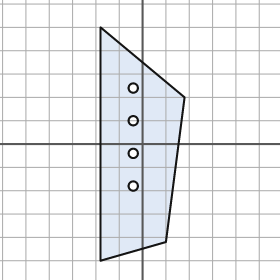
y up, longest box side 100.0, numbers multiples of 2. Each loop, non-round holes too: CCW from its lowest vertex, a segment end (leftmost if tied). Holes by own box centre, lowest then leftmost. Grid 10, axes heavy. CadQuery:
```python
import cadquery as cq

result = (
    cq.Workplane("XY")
    .moveTo(-18.0, -50.0)
    .lineTo(10.0, -42.0)
    .lineTo(18.0, 20.0)
    .lineTo(-18.0, 50.0)
    .close()
    .moveTo(-4.0, -18.0)
    .circle(2.0)
    .moveTo(-4.0, -4.0)
    .circle(2.0)
    .moveTo(-4.0, 10.0)
    .circle(2.0)
    .moveTo(-4.0, 24.0)
    .circle(2.0)
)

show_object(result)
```